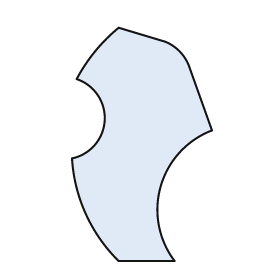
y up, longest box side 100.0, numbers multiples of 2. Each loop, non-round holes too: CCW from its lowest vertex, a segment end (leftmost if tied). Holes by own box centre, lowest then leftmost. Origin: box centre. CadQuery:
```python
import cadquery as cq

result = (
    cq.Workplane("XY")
    .moveTo(-10.0, -50.0)
    .lineTo(14.0, -50.0)
    .threePointArc((8.0, -18.0), (30.0, 6.0))
    .lineTo(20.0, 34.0)
    .threePointArc((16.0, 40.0), (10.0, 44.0))
    .lineTo(-10.0, 50.0)
    .threePointArc((-20.0, 40.0), (-28.0, 28.0))
    .threePointArc((-16.0, 10.0), (-30.0, -6.0))
    .threePointArc((-24.0, -30.0), (-10.0, -50.0))
    .close()
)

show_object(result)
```